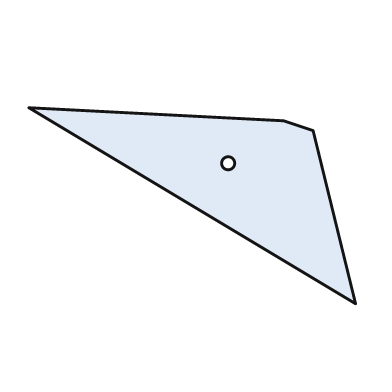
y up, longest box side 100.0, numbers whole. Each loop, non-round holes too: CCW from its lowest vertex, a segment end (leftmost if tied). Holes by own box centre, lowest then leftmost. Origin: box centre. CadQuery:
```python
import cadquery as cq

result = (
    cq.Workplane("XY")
    .moveTo(50.0, -30.0)
    .lineTo(37.0, 23.0)
    .lineTo(28.0, 26.0)
    .lineTo(-50.0, 30.0)
    .close()
    .moveTo(11.0, 13.0)
    .circle(2.0)
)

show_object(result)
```